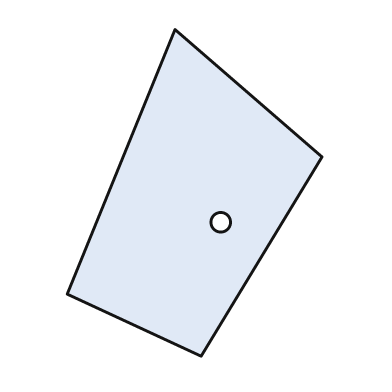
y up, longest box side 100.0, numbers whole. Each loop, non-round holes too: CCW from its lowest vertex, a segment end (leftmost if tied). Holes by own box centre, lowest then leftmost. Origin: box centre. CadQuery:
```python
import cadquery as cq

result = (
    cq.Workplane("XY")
    .moveTo(2.0, -50.0)
    .lineTo(39.0, 11.0)
    .lineTo(-6.0, 50.0)
    .lineTo(-39.0, -31.0)
    .close()
    .moveTo(8.0, -9.0)
    .circle(3.0)
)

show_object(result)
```